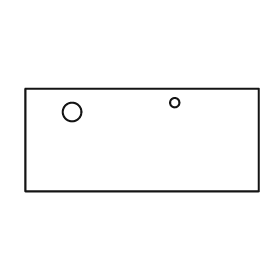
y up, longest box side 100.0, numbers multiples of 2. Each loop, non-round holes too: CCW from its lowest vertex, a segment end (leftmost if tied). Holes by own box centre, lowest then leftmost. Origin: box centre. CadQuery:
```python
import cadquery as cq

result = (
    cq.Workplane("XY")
    .moveTo(-50.0, -22.0)
    .lineTo(50.0, -22.0)
    .lineTo(50.0, 22.0)
    .lineTo(-50.0, 22.0)
    .close()
    .moveTo(-30.0, 12.0)
    .circle(4.0)
    .moveTo(14.0, 16.0)
    .circle(2.0)
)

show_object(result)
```